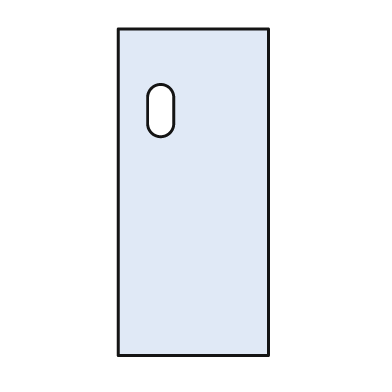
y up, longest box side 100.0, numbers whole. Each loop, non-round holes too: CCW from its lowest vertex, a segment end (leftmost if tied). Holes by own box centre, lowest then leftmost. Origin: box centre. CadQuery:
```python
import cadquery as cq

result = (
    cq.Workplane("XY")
    .moveTo(-23.0, -50.0)
    .lineTo(23.0, -50.0)
    .lineTo(23.0, 50.0)
    .lineTo(-23.0, 50.0)
    .close()
    .moveTo(-14.0, 21.0)
    .threePointArc((-10.0, 17.0), (-6.0, 21.0))
    .lineTo(-6.0, 29.0)
    .threePointArc((-10.0, 33.0), (-14.0, 29.0))
    .close()
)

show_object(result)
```